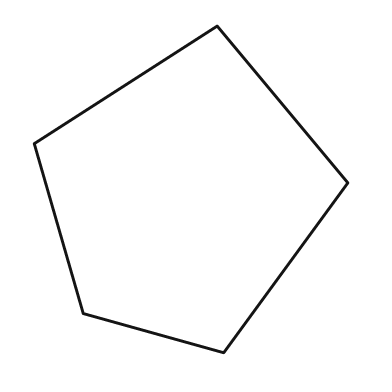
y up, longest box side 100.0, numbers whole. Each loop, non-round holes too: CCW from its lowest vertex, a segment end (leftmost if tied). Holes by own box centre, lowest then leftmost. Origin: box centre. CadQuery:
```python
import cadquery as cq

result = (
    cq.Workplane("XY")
    .moveTo(10.0, -50.0)
    .lineTo(48.0, 2.0)
    .lineTo(8.0, 50.0)
    .lineTo(-48.0, 14.0)
    .lineTo(-33.0, -38.0)
    .close()
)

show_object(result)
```